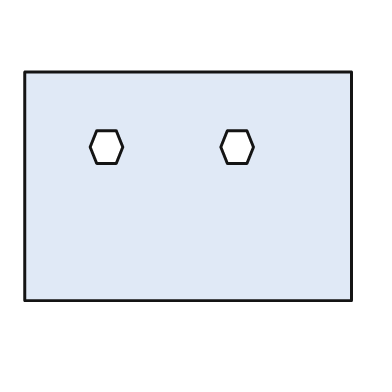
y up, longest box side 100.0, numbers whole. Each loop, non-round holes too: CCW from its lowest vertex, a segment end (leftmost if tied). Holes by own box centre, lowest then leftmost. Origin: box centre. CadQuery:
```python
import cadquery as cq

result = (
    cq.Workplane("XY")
    .moveTo(-50.0, -35.0)
    .lineTo(50.0, -35.0)
    .lineTo(50.0, 35.0)
    .lineTo(-50.0, 35.0)
    .close()
    .moveTo(-28.0, 7.0)
    .lineTo(-22.0, 7.0)
    .lineTo(-20.0, 12.0)
    .lineTo(-22.0, 17.0)
    .lineTo(-28.0, 17.0)
    .lineTo(-30.0, 12.0)
    .close()
    .moveTo(12.0, 7.0)
    .lineTo(18.0, 7.0)
    .lineTo(20.0, 12.0)
    .lineTo(18.0, 17.0)
    .lineTo(12.0, 17.0)
    .lineTo(10.0, 12.0)
    .close()
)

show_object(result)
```